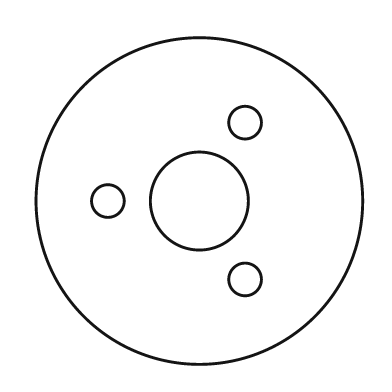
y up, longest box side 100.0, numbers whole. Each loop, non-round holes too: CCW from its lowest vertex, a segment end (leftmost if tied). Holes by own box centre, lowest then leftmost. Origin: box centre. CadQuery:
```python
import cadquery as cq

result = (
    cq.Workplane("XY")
    .moveTo(0.0, 0.0)
    .circle(50.0)
    .moveTo(14.0, -24.0)
    .circle(5.0)
    .moveTo(-28.0, 0.0)
    .circle(5.0)
    .moveTo(0.0, 0.0)
    .circle(15.0)
    .moveTo(14.0, 24.0)
    .circle(5.0)
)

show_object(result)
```